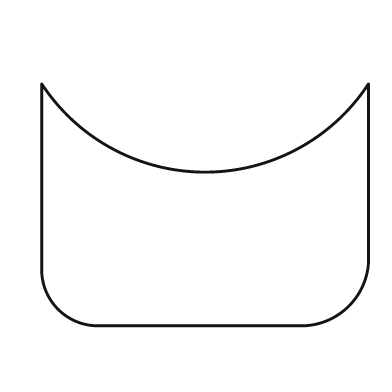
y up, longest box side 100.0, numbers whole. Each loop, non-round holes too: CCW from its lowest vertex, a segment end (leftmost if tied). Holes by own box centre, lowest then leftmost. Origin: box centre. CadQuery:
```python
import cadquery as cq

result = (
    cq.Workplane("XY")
    .moveTo(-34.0, -37.0)
    .lineTo(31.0, -37.0)
    .threePointArc((44.0, -31.0), (50.0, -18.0))
    .lineTo(50.0, 37.0)
    .threePointArc((0.0, 10.0), (-50.0, 37.0))
    .lineTo(-50.0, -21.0)
    .threePointArc((-45.0, -32.0), (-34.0, -37.0))
    .close()
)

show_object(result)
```